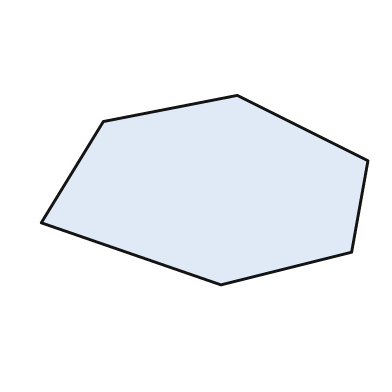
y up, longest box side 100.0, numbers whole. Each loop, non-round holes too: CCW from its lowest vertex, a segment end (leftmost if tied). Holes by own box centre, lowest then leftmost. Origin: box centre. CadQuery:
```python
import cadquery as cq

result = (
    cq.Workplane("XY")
    .moveTo(5.0, -29.0)
    .lineTo(45.0, -19.0)
    .lineTo(50.0, 9.0)
    .lineTo(10.0, 29.0)
    .lineTo(-31.0, 21.0)
    .lineTo(-50.0, -10.0)
    .close()
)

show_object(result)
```